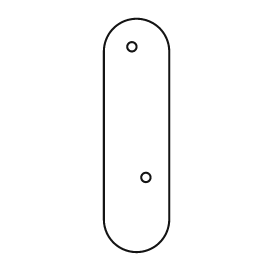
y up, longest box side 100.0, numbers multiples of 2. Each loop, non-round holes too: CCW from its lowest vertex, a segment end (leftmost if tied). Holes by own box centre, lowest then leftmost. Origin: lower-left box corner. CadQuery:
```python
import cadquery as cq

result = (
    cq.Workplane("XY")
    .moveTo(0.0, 14.0)
    .threePointArc((14.0, 0.0), (28.0, 14.0))
    .lineTo(28.0, 86.0)
    .threePointArc((14.0, 100.0), (0.0, 86.0))
    .close()
    .moveTo(18.0, 32.0)
    .circle(2.0)
    .moveTo(12.0, 88.0)
    .circle(2.0)
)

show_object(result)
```